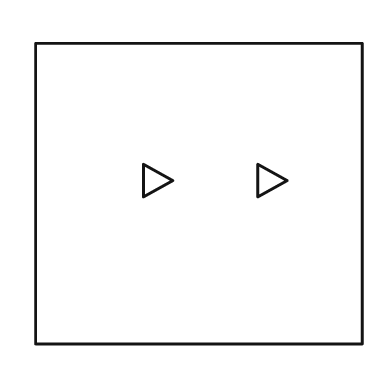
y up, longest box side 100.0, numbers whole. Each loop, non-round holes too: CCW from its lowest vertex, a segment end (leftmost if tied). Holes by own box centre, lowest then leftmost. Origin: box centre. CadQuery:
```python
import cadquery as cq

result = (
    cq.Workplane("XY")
    .moveTo(-50.0, -46.0)
    .lineTo(50.0, -46.0)
    .lineTo(50.0, 46.0)
    .lineTo(-50.0, 46.0)
    .close()
    .moveTo(-17.0, -1.0)
    .lineTo(-8.0, 4.0)
    .lineTo(-17.0, 9.0)
    .close()
    .moveTo(18.0, -1.0)
    .lineTo(27.0, 4.0)
    .lineTo(18.0, 9.0)
    .close()
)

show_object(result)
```